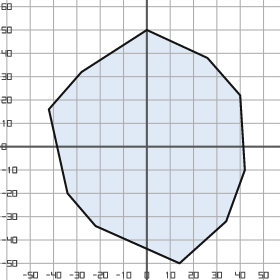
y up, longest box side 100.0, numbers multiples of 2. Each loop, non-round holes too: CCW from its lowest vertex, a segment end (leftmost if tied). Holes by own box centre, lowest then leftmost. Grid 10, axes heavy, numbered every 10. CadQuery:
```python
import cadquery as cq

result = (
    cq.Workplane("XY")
    .moveTo(14.0, -50.0)
    .lineTo(34.0, -32.0)
    .lineTo(42.0, -10.0)
    .lineTo(40.0, 22.0)
    .lineTo(26.0, 38.0)
    .lineTo(0.0, 50.0)
    .lineTo(-28.0, 32.0)
    .lineTo(-42.0, 16.0)
    .lineTo(-34.0, -20.0)
    .lineTo(-22.0, -34.0)
    .close()
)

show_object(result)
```